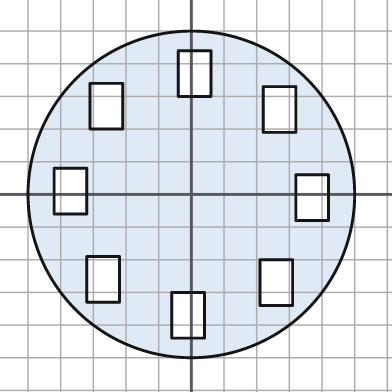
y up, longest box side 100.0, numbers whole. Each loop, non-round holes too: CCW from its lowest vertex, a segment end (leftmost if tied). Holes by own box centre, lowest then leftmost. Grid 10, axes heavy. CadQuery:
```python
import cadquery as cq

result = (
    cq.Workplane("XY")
    .moveTo(0.0, 0.0)
    .circle(50.0)
    .moveTo(-6.0, -44.0)
    .lineTo(4.0, -44.0)
    .lineTo(4.0, -30.0)
    .lineTo(-6.0, -30.0)
    .close()
    .moveTo(21.0, -34.0)
    .lineTo(31.0, -34.0)
    .lineTo(31.0, -20.0)
    .lineTo(21.0, -20.0)
    .close()
    .moveTo(-32.0, -33.0)
    .lineTo(-22.0, -33.0)
    .lineTo(-22.0, -19.0)
    .lineTo(-32.0, -19.0)
    .close()
    .moveTo(32.0, -8.0)
    .lineTo(42.0, -8.0)
    .lineTo(42.0, 6.0)
    .lineTo(32.0, 6.0)
    .close()
    .moveTo(-42.0, -6.0)
    .lineTo(-32.0, -6.0)
    .lineTo(-32.0, 8.0)
    .lineTo(-42.0, 8.0)
    .close()
    .moveTo(22.0, 19.0)
    .lineTo(32.0, 19.0)
    .lineTo(32.0, 33.0)
    .lineTo(22.0, 33.0)
    .close()
    .moveTo(-31.0, 20.0)
    .lineTo(-21.0, 20.0)
    .lineTo(-21.0, 34.0)
    .lineTo(-31.0, 34.0)
    .close()
    .moveTo(-4.0, 30.0)
    .lineTo(6.0, 30.0)
    .lineTo(6.0, 44.0)
    .lineTo(-4.0, 44.0)
    .close()
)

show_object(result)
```